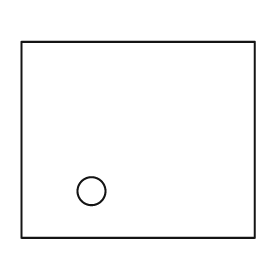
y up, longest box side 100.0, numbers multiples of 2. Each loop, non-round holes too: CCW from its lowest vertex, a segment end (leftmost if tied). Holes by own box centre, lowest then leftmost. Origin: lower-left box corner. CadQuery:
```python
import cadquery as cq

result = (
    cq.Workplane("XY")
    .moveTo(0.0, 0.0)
    .lineTo(100.0, 0.0)
    .lineTo(100.0, 84.0)
    .lineTo(0.0, 84.0)
    .close()
    .moveTo(30.0, 20.0)
    .circle(6.0)
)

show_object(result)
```